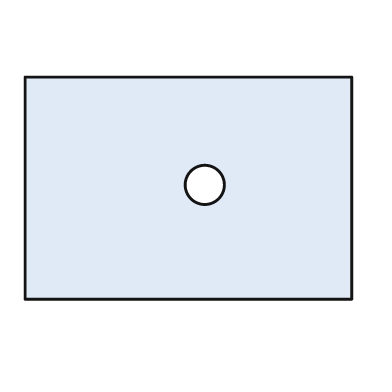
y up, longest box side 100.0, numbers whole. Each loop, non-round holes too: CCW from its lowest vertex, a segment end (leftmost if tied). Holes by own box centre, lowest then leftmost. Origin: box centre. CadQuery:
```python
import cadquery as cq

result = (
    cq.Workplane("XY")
    .moveTo(-50.0, -34.0)
    .lineTo(50.0, -34.0)
    .lineTo(50.0, 34.0)
    .lineTo(-50.0, 34.0)
    .close()
    .moveTo(5.0, 1.0)
    .circle(6.0)
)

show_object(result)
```